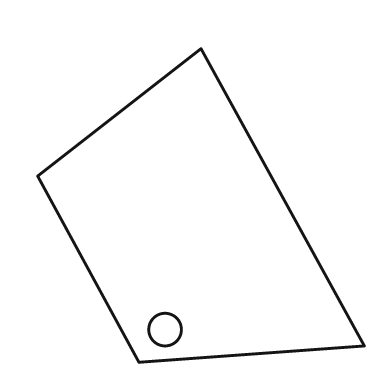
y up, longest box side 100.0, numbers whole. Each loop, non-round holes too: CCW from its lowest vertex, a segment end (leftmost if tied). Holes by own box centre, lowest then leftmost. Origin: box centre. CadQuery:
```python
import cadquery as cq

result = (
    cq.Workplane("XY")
    .moveTo(-19.0, -48.0)
    .lineTo(50.0, -43.0)
    .lineTo(0.0, 48.0)
    .lineTo(-50.0, 9.0)
    .close()
    .moveTo(-11.0, -38.0)
    .circle(5.0)
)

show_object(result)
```